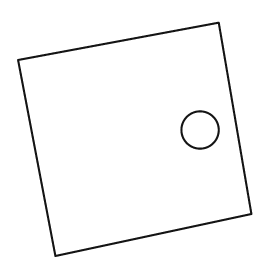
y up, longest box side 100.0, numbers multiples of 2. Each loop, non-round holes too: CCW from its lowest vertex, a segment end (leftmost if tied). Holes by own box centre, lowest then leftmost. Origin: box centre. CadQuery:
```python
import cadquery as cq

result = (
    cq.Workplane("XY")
    .moveTo(-34.0, -50.0)
    .lineTo(50.0, -32.0)
    .lineTo(36.0, 50.0)
    .lineTo(-50.0, 34.0)
    .close()
    .moveTo(28.0, 4.0)
    .circle(8.0)
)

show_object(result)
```